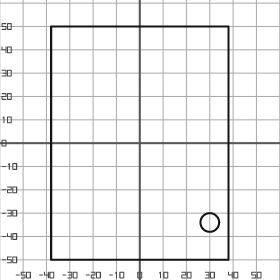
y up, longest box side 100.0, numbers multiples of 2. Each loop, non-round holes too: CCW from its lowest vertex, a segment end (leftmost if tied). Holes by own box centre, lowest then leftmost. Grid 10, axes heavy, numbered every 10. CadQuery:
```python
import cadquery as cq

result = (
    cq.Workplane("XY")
    .moveTo(-38.0, -50.0)
    .lineTo(38.0, -50.0)
    .lineTo(38.0, 50.0)
    .lineTo(-38.0, 50.0)
    .close()
    .moveTo(30.0, -34.0)
    .circle(4.0)
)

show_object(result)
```